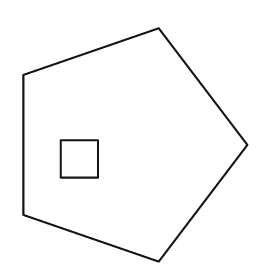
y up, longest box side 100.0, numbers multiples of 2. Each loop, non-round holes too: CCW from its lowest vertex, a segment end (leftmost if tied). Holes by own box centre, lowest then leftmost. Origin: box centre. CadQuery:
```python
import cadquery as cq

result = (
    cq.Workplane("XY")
    .moveTo(10.0, -50.0)
    .lineTo(48.0, 0.0)
    .lineTo(10.0, 50.0)
    .lineTo(-48.0, 30.0)
    .lineTo(-48.0, -30.0)
    .close()
    .moveTo(-32.0, -14.0)
    .lineTo(-16.0, -14.0)
    .lineTo(-16.0, 2.0)
    .lineTo(-32.0, 2.0)
    .close()
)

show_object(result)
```